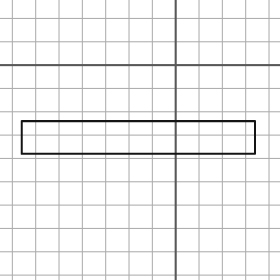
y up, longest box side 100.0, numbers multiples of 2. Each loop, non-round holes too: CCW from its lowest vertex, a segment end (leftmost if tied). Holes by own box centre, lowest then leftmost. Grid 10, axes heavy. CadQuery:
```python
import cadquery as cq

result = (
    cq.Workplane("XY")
    .moveTo(-66.0, -38.0)
    .lineTo(34.0, -38.0)
    .lineTo(34.0, -24.0)
    .lineTo(-66.0, -24.0)
    .close()
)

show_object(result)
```